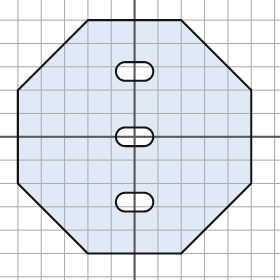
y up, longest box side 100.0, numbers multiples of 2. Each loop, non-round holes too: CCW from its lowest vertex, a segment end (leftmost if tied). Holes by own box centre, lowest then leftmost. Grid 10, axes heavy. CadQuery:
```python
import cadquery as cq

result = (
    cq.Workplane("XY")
    .moveTo(-20.0, -50.0)
    .lineTo(20.0, -50.0)
    .lineTo(50.0, -20.0)
    .lineTo(50.0, 20.0)
    .lineTo(20.0, 50.0)
    .lineTo(-20.0, 50.0)
    .lineTo(-50.0, 20.0)
    .lineTo(-50.0, -20.0)
    .close()
    .moveTo(-4.0, -32.0)
    .lineTo(4.0, -32.0)
    .threePointArc((8.0, -28.0), (4.0, -24.0))
    .lineTo(-4.0, -24.0)
    .threePointArc((-8.0, -28.0), (-4.0, -32.0))
    .close()
    .moveTo(-4.0, -4.0)
    .lineTo(4.0, -4.0)
    .threePointArc((8.0, 0.0), (4.0, 4.0))
    .lineTo(-4.0, 4.0)
    .threePointArc((-8.0, 0.0), (-4.0, -4.0))
    .close()
    .moveTo(-4.0, 24.0)
    .lineTo(4.0, 24.0)
    .threePointArc((8.0, 28.0), (4.0, 32.0))
    .lineTo(-4.0, 32.0)
    .threePointArc((-8.0, 28.0), (-4.0, 24.0))
    .close()
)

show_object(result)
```